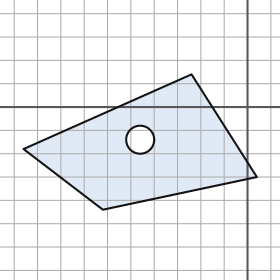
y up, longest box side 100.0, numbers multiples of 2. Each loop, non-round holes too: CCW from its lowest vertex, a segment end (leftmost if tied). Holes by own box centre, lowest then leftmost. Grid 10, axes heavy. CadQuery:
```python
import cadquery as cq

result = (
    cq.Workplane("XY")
    .moveTo(-62.0, -44.0)
    .lineTo(4.0, -30.0)
    .lineTo(-24.0, 14.0)
    .lineTo(-96.0, -18.0)
    .close()
    .moveTo(-46.0, -14.0)
    .circle(6.0)
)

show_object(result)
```